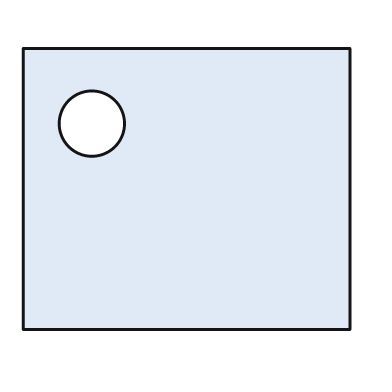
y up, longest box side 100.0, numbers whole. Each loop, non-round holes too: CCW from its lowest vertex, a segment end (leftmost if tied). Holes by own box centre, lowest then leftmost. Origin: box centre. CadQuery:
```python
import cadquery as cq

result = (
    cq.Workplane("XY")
    .moveTo(-50.0, -43.0)
    .lineTo(50.0, -43.0)
    .lineTo(50.0, 43.0)
    .lineTo(-50.0, 43.0)
    .close()
    .moveTo(-29.0, 20.0)
    .circle(10.0)
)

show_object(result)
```